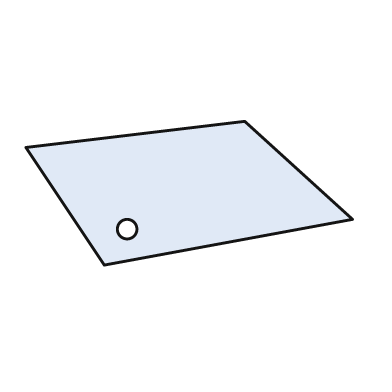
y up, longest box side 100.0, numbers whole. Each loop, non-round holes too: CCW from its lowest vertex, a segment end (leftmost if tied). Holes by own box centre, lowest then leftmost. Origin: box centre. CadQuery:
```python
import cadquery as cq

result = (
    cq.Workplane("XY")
    .moveTo(-26.0, -22.0)
    .lineTo(50.0, -8.0)
    .lineTo(17.0, 22.0)
    .lineTo(-50.0, 14.0)
    .close()
    .moveTo(-19.0, -11.0)
    .circle(3.0)
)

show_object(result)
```